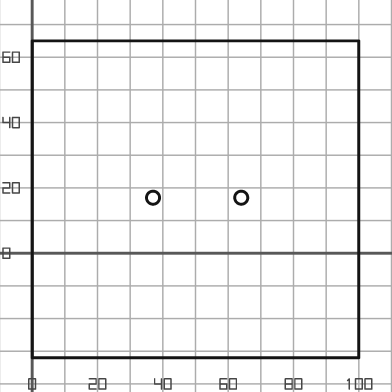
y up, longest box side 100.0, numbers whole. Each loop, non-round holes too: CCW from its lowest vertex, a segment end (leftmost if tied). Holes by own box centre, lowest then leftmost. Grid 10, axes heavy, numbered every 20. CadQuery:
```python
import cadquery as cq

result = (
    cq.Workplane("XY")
    .moveTo(0.0, -32.0)
    .lineTo(100.0, -32.0)
    .lineTo(100.0, 65.0)
    .lineTo(0.0, 65.0)
    .close()
    .moveTo(37.0, 17.0)
    .circle(2.0)
    .moveTo(64.0, 17.0)
    .circle(2.0)
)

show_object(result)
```